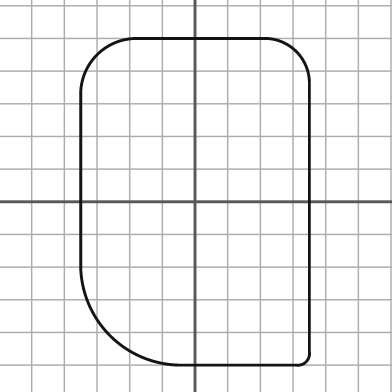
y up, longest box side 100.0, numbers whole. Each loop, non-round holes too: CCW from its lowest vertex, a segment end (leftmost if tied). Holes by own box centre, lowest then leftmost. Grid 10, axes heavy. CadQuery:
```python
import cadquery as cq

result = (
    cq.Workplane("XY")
    .moveTo(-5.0, -50.0)
    .lineTo(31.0, -50.0)
    .threePointArc((34.0, -49.0), (35.0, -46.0))
    .lineTo(35.0, 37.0)
    .threePointArc((31.0, 46.0), (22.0, 50.0))
    .lineTo(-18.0, 50.0)
    .threePointArc((-30.0, 45.0), (-35.0, 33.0))
    .lineTo(-35.0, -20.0)
    .threePointArc((-26.0, -41.0), (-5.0, -50.0))
    .close()
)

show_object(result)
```